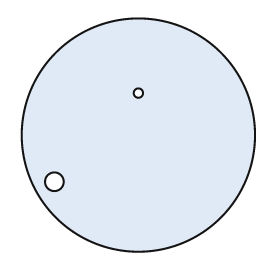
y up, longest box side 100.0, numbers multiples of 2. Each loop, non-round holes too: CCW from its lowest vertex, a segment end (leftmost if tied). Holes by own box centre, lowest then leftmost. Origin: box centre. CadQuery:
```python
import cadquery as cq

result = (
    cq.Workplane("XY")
    .moveTo(0.0, 0.0)
    .circle(50.0)
    .moveTo(-36.0, -20.0)
    .circle(4.0)
    .moveTo(0.0, 18.0)
    .circle(2.0)
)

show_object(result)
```